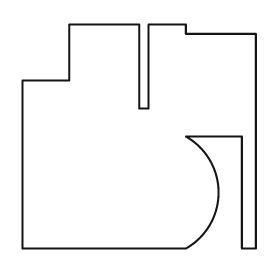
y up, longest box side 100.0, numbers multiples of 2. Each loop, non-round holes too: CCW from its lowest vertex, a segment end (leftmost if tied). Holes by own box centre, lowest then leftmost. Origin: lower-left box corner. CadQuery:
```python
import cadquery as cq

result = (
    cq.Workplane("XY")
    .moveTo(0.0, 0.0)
    .lineTo(70.0, 0.0)
    .threePointArc((84.0, 24.0), (70.0, 48.0))
    .lineTo(94.0, 48.0)
    .lineTo(94.0, 0.0)
    .lineTo(100.0, 0.0)
    .lineTo(100.0, 92.0)
    .lineTo(70.0, 92.0)
    .lineTo(70.0, 96.0)
    .lineTo(54.0, 96.0)
    .lineTo(54.0, 60.0)
    .lineTo(50.0, 60.0)
    .lineTo(50.0, 96.0)
    .lineTo(20.0, 96.0)
    .lineTo(20.0, 72.0)
    .lineTo(0.0, 72.0)
    .close()
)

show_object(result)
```